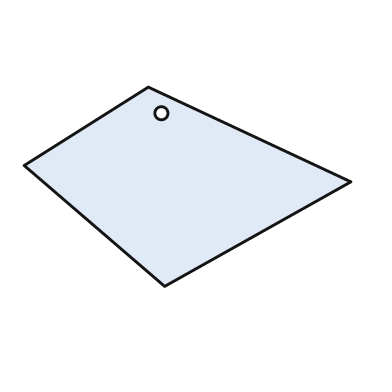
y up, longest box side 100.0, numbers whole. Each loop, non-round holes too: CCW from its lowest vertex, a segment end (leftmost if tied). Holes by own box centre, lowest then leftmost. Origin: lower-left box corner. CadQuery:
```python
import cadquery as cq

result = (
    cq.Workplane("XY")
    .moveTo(43.0, 0.0)
    .lineTo(100.0, 32.0)
    .lineTo(38.0, 61.0)
    .lineTo(0.0, 37.0)
    .close()
    .moveTo(42.0, 53.0)
    .circle(2.0)
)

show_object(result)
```